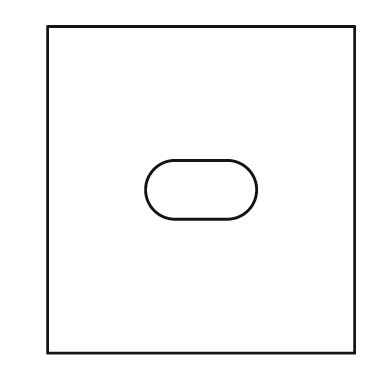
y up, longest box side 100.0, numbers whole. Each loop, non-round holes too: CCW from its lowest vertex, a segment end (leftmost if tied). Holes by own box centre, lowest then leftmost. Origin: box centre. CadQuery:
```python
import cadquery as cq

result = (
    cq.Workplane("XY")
    .moveTo(-47.0, -50.0)
    .lineTo(47.0, -50.0)
    .lineTo(47.0, 50.0)
    .lineTo(-47.0, 50.0)
    .close()
    .moveTo(-8.0, -9.0)
    .lineTo(8.0, -9.0)
    .threePointArc((17.0, 0.0), (8.0, 9.0))
    .lineTo(-8.0, 9.0)
    .threePointArc((-17.0, 0.0), (-8.0, -9.0))
    .close()
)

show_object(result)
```